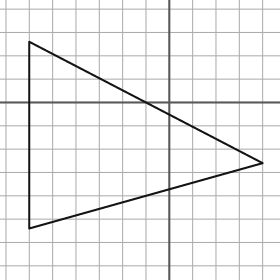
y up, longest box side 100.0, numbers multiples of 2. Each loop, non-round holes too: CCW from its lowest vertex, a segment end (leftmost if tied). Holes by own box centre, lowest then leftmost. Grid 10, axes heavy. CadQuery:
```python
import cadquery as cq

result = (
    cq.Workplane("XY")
    .moveTo(-60.0, -54.0)
    .lineTo(40.0, -26.0)
    .lineTo(-60.0, 26.0)
    .close()
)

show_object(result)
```